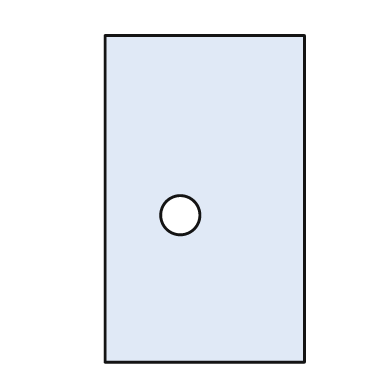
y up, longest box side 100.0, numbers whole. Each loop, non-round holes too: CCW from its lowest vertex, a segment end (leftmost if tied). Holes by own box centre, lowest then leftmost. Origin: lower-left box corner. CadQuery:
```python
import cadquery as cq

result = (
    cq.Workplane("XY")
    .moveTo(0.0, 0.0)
    .lineTo(61.0, 0.0)
    .lineTo(61.0, 100.0)
    .lineTo(0.0, 100.0)
    .close()
    .moveTo(23.0, 45.0)
    .circle(6.0)
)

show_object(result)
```